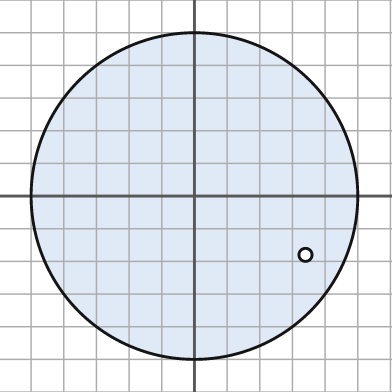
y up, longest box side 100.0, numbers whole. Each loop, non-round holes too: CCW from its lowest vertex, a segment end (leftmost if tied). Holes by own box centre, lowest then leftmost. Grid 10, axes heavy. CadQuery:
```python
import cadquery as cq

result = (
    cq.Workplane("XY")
    .moveTo(0.0, 0.0)
    .circle(50.0)
    .moveTo(34.0, -18.0)
    .circle(2.0)
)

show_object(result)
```